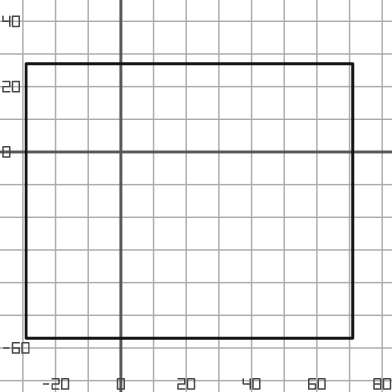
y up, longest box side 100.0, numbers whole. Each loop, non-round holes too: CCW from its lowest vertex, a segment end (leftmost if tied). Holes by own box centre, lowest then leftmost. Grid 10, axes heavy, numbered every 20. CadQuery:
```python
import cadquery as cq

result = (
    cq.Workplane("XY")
    .moveTo(-29.0, -57.0)
    .lineTo(71.0, -57.0)
    .lineTo(71.0, 27.0)
    .lineTo(-29.0, 27.0)
    .close()
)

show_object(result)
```